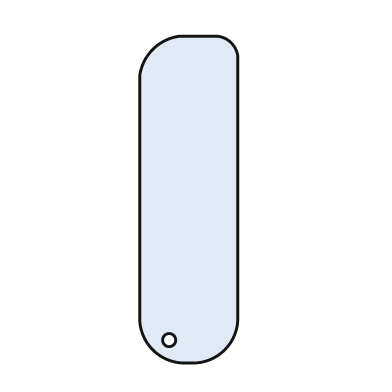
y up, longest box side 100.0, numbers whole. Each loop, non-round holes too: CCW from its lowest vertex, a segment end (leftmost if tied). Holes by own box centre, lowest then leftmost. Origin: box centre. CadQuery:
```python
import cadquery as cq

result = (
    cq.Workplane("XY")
    .moveTo(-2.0, -50.0)
    .lineTo(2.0, -50.0)
    .threePointArc((11.0, -46.0), (15.0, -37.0))
    .lineTo(15.0, 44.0)
    .threePointArc((13.0, 48.0), (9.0, 50.0))
    .lineTo(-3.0, 50.0)
    .threePointArc((-11.0, 46.0), (-15.0, 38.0))
    .lineTo(-15.0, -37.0)
    .threePointArc((-11.0, -46.0), (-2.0, -50.0))
    .close()
    .moveTo(-6.0, -43.0)
    .circle(2.0)
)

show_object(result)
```